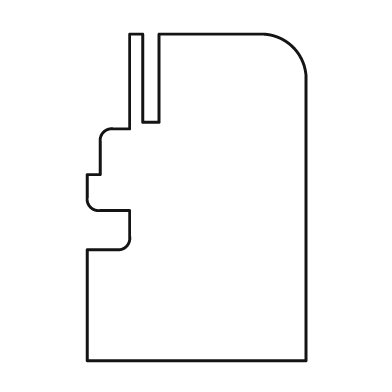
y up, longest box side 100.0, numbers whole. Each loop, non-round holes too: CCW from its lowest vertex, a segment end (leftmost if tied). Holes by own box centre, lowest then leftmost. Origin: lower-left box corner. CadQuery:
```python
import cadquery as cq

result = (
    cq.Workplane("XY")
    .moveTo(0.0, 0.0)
    .lineTo(67.0, 0.0)
    .lineTo(67.0, 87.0)
    .threePointArc((63.0, 96.0), (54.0, 100.0))
    .lineTo(22.0, 100.0)
    .lineTo(22.0, 73.0)
    .lineTo(17.0, 73.0)
    .lineTo(17.0, 100.0)
    .lineTo(13.0, 100.0)
    .lineTo(13.0, 71.0)
    .lineTo(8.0, 71.0)
    .threePointArc((5.0, 70.0), (4.0, 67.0))
    .lineTo(4.0, 57.0)
    .lineTo(0.0, 57.0)
    .lineTo(0.0, 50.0)
    .threePointArc((1.0, 47.0), (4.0, 46.0))
    .lineTo(13.0, 46.0)
    .lineTo(13.0, 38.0)
    .threePointArc((12.0, 35.0), (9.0, 34.0))
    .lineTo(0.0, 34.0)
    .close()
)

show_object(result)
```